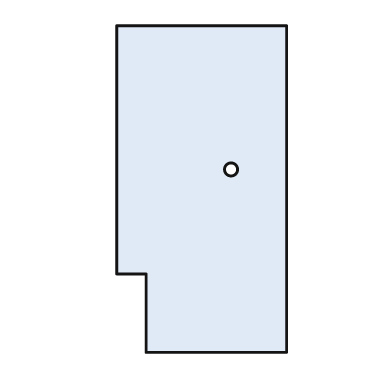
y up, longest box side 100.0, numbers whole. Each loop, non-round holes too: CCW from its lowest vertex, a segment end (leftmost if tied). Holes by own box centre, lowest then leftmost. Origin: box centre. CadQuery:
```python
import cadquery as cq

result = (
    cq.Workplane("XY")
    .moveTo(-17.0, -50.0)
    .lineTo(26.0, -50.0)
    .lineTo(26.0, 50.0)
    .lineTo(-26.0, 50.0)
    .lineTo(-26.0, -26.0)
    .lineTo(-17.0, -26.0)
    .close()
    .moveTo(9.0, 6.0)
    .circle(2.0)
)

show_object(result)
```